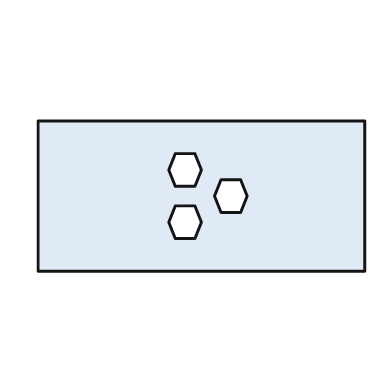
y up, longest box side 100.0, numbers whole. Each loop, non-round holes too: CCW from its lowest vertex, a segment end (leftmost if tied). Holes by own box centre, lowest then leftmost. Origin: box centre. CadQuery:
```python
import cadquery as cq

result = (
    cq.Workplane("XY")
    .moveTo(-50.0, -23.0)
    .lineTo(50.0, -23.0)
    .lineTo(50.0, 23.0)
    .lineTo(-50.0, 23.0)
    .close()
    .moveTo(-8.0, -13.0)
    .lineTo(-2.0, -13.0)
    .lineTo(0.0, -8.0)
    .lineTo(-2.0, -3.0)
    .lineTo(-8.0, -3.0)
    .lineTo(-10.0, -8.0)
    .close()
    .moveTo(6.0, -5.0)
    .lineTo(12.0, -5.0)
    .lineTo(14.0, 0.0)
    .lineTo(12.0, 5.0)
    .lineTo(6.0, 5.0)
    .lineTo(4.0, 0.0)
    .close()
    .moveTo(-8.0, 3.0)
    .lineTo(-2.0, 3.0)
    .lineTo(0.0, 8.0)
    .lineTo(-2.0, 13.0)
    .lineTo(-8.0, 13.0)
    .lineTo(-10.0, 8.0)
    .close()
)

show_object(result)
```